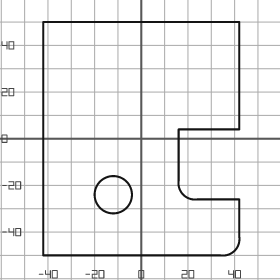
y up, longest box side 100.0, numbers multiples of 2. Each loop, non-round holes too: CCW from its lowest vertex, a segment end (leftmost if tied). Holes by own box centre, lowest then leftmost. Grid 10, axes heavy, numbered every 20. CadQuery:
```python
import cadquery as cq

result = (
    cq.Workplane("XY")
    .moveTo(-42.0, -50.0)
    .lineTo(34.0, -50.0)
    .threePointArc((40.0, -48.0), (42.0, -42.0))
    .lineTo(42.0, -26.0)
    .lineTo(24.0, -26.0)
    .threePointArc((18.0, -24.0), (16.0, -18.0))
    .lineTo(16.0, 4.0)
    .lineTo(42.0, 4.0)
    .lineTo(42.0, 50.0)
    .lineTo(-42.0, 50.0)
    .close()
    .moveTo(-12.0, -24.0)
    .circle(8.0)
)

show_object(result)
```